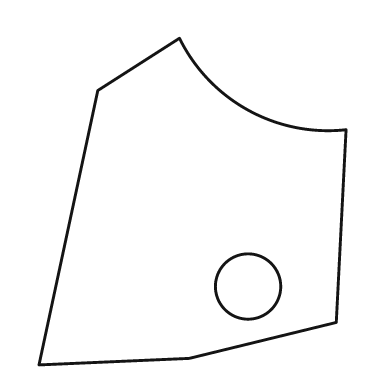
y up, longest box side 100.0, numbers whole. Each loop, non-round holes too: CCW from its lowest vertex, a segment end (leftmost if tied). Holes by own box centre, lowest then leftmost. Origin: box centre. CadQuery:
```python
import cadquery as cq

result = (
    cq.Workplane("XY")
    .moveTo(-47.0, -50.0)
    .lineTo(-1.0, -48.0)
    .lineTo(44.0, -37.0)
    .lineTo(47.0, 22.0)
    .threePointArc((17.0, 28.0), (-4.0, 50.0))
    .lineTo(-29.0, 34.0)
    .close()
    .moveTo(17.0, -26.0)
    .circle(10.0)
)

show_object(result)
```